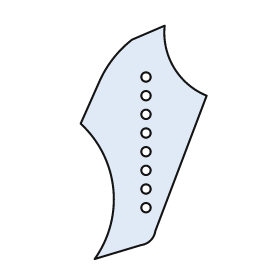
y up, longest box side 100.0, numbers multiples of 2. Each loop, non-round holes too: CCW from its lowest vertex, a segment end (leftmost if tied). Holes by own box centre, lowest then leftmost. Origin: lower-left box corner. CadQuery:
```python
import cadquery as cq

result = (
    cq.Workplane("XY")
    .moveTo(6.0, 0.0)
    .lineTo(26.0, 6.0)
    .threePointArc((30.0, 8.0), (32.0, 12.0))
    .lineTo(54.0, 70.0)
    .threePointArc((40.0, 82.0), (36.0, 100.0))
    .lineTo(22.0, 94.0)
    .threePointArc((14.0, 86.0), (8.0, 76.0))
    .lineTo(0.0, 58.0)
    .threePointArc((14.0, 30.0), (6.0, 0.0))
    .close()
    .moveTo(28.0, 22.0)
    .circle(2.0)
    .moveTo(28.0, 30.0)
    .circle(2.0)
    .moveTo(28.0, 38.0)
    .circle(2.0)
    .moveTo(28.0, 46.0)
    .circle(2.0)
    .moveTo(28.0, 54.0)
    .circle(2.0)
    .moveTo(28.0, 62.0)
    .circle(2.0)
    .moveTo(28.0, 70.0)
    .circle(2.0)
    .moveTo(28.0, 78.0)
    .circle(2.0)
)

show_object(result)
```